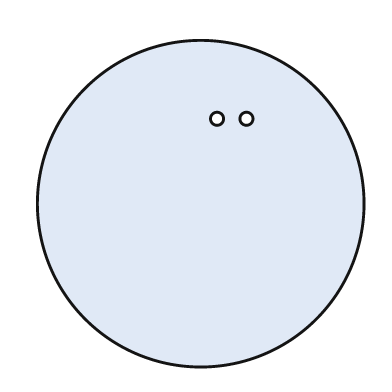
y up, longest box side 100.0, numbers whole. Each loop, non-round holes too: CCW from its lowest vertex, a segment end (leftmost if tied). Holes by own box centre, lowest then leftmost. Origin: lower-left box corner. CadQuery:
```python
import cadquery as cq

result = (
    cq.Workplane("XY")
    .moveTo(50.0, 50.0)
    .circle(50.0)
    .moveTo(55.0, 76.0)
    .circle(2.0)
    .moveTo(64.0, 76.0)
    .circle(2.0)
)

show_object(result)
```